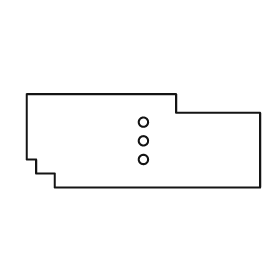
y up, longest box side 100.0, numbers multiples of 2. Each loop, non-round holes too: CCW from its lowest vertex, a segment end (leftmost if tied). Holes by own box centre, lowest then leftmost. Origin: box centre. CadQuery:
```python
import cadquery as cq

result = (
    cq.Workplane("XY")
    .moveTo(-38.0, -20.0)
    .lineTo(50.0, -20.0)
    .lineTo(50.0, 12.0)
    .lineTo(14.0, 12.0)
    .lineTo(14.0, 20.0)
    .lineTo(-50.0, 20.0)
    .lineTo(-50.0, -8.0)
    .lineTo(-46.0, -8.0)
    .lineTo(-46.0, -14.0)
    .lineTo(-38.0, -14.0)
    .close()
    .moveTo(0.0, -8.0)
    .circle(2.0)
    .moveTo(0.0, 0.0)
    .circle(2.0)
    .moveTo(0.0, 8.0)
    .circle(2.0)
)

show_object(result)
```